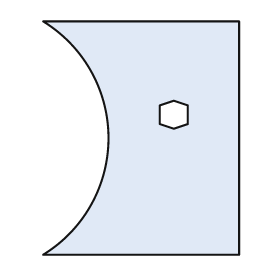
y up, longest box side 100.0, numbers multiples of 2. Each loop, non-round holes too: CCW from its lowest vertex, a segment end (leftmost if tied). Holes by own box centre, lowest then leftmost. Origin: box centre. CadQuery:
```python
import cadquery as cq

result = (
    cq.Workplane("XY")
    .moveTo(-42.0, -50.0)
    .lineTo(42.0, -50.0)
    .lineTo(42.0, 50.0)
    .lineTo(-42.0, 50.0)
    .threePointArc((-14.0, 0.0), (-42.0, -50.0))
    .close()
    .moveTo(14.0, 4.0)
    .lineTo(20.0, 6.0)
    .lineTo(20.0, 14.0)
    .lineTo(14.0, 16.0)
    .lineTo(8.0, 14.0)
    .lineTo(8.0, 6.0)
    .close()
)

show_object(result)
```